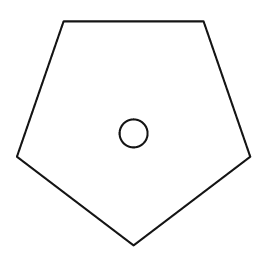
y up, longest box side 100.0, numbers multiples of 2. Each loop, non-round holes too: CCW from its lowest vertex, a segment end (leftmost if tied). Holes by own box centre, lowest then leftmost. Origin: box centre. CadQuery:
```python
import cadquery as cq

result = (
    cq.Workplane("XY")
    .moveTo(0.0, -48.0)
    .lineTo(50.0, -10.0)
    .lineTo(30.0, 48.0)
    .lineTo(-30.0, 48.0)
    .lineTo(-50.0, -10.0)
    .close()
    .moveTo(0.0, 0.0)
    .circle(6.0)
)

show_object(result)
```